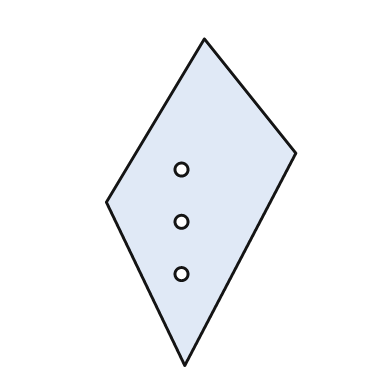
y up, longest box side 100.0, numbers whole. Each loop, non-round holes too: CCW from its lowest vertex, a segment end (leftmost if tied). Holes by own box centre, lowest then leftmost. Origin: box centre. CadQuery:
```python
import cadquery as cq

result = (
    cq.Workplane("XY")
    .moveTo(-5.0, -50.0)
    .lineTo(29.0, 15.0)
    .lineTo(1.0, 50.0)
    .lineTo(-29.0, 0.0)
    .close()
    .moveTo(-6.0, -22.0)
    .circle(2.0)
    .moveTo(-6.0, -6.0)
    .circle(2.0)
    .moveTo(-6.0, 10.0)
    .circle(2.0)
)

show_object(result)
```